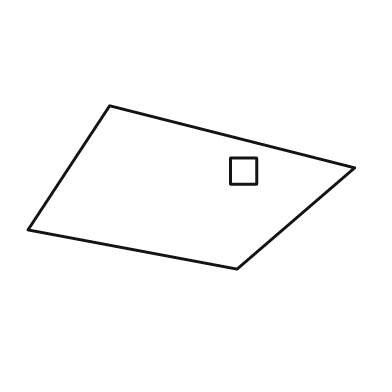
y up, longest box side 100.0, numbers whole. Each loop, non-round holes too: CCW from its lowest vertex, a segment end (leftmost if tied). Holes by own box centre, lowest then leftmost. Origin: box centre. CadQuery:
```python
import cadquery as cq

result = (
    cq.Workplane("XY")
    .moveTo(14.0, -25.0)
    .lineTo(50.0, 6.0)
    .lineTo(-25.0, 25.0)
    .lineTo(-50.0, -13.0)
    .close()
    .moveTo(12.0, 1.0)
    .lineTo(20.0, 1.0)
    .lineTo(20.0, 9.0)
    .lineTo(12.0, 9.0)
    .close()
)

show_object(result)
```